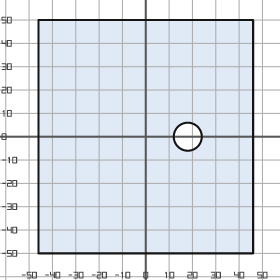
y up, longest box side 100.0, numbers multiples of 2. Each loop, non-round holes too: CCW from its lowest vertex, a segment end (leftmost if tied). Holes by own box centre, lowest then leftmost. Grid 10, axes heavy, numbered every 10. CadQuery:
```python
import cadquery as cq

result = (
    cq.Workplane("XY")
    .moveTo(-46.0, -50.0)
    .lineTo(46.0, -50.0)
    .lineTo(46.0, 50.0)
    .lineTo(-46.0, 50.0)
    .close()
    .moveTo(18.0, 0.0)
    .circle(6.0)
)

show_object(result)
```